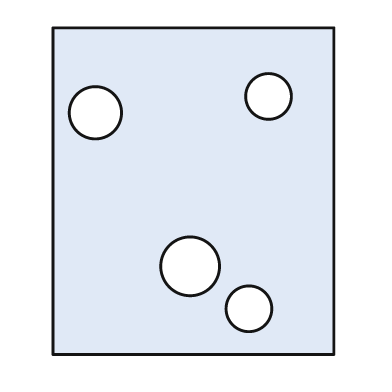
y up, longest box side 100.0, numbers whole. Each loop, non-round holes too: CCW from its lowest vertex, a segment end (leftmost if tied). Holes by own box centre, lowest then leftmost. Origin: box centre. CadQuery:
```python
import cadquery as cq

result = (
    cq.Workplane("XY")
    .moveTo(-43.0, -50.0)
    .lineTo(43.0, -50.0)
    .lineTo(43.0, 50.0)
    .lineTo(-43.0, 50.0)
    .close()
    .moveTo(17.0, -36.0)
    .circle(7.0)
    .moveTo(-1.0, -23.0)
    .circle(9.0)
    .moveTo(-30.0, 24.0)
    .circle(8.0)
    .moveTo(23.0, 29.0)
    .circle(7.0)
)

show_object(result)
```